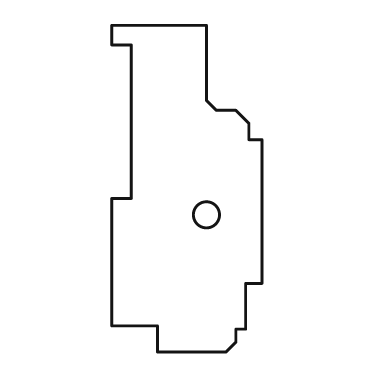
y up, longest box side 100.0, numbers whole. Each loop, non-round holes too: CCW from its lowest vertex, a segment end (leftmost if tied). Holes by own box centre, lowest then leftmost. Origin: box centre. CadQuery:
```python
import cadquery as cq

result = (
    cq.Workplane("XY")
    .moveTo(-9.0, -50.0)
    .lineTo(12.0, -50.0)
    .lineTo(15.0, -47.0)
    .lineTo(15.0, -43.0)
    .lineTo(18.0, -43.0)
    .lineTo(18.0, -29.0)
    .lineTo(23.0, -29.0)
    .lineTo(23.0, 15.0)
    .lineTo(19.0, 15.0)
    .lineTo(19.0, 20.0)
    .lineTo(15.0, 24.0)
    .lineTo(9.0, 24.0)
    .lineTo(6.0, 27.0)
    .lineTo(6.0, 50.0)
    .lineTo(-23.0, 50.0)
    .lineTo(-23.0, 44.0)
    .lineTo(-17.0, 44.0)
    .lineTo(-17.0, -3.0)
    .lineTo(-23.0, -3.0)
    .lineTo(-23.0, -42.0)
    .lineTo(-9.0, -42.0)
    .close()
    .moveTo(6.0, -8.0)
    .circle(4.0)
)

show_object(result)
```